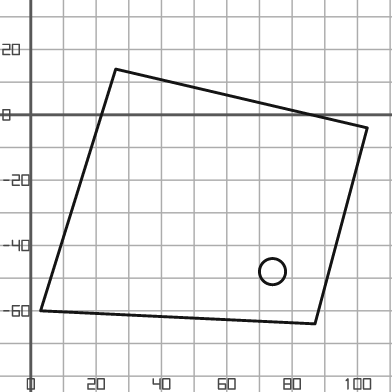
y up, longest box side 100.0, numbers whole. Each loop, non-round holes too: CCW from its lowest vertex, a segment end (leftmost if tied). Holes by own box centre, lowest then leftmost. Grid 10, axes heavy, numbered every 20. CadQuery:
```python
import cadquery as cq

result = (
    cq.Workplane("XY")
    .moveTo(87.0, -64.0)
    .lineTo(103.0, -4.0)
    .lineTo(26.0, 14.0)
    .lineTo(3.0, -60.0)
    .close()
    .moveTo(74.0, -48.0)
    .circle(4.0)
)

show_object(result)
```